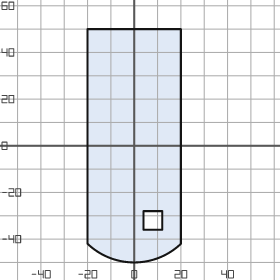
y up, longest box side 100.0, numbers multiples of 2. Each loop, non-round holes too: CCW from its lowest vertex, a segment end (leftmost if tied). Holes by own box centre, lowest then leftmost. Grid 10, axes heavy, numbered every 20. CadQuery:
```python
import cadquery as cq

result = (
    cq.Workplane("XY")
    .moveTo(-20.0, -42.0)
    .threePointArc((0.0, -50.0), (20.0, -42.0))
    .lineTo(20.0, 50.0)
    .lineTo(-20.0, 50.0)
    .close()
    .moveTo(4.0, -36.0)
    .lineTo(12.0, -36.0)
    .lineTo(12.0, -28.0)
    .lineTo(4.0, -28.0)
    .close()
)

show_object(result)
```